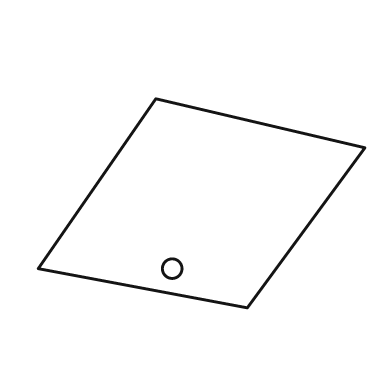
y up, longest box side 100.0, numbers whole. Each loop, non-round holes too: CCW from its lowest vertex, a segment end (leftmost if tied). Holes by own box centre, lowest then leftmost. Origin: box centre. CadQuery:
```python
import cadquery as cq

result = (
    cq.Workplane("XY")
    .moveTo(14.0, -32.0)
    .lineTo(50.0, 17.0)
    .lineTo(-14.0, 32.0)
    .lineTo(-50.0, -20.0)
    .close()
    .moveTo(-9.0, -20.0)
    .circle(3.0)
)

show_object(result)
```